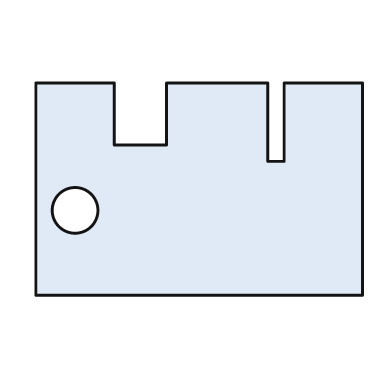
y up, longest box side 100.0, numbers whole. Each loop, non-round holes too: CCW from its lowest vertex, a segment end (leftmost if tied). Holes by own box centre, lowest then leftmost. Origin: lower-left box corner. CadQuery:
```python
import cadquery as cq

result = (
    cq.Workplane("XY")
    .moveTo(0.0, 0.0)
    .lineTo(100.0, 0.0)
    .lineTo(100.0, 65.0)
    .lineTo(76.0, 65.0)
    .lineTo(76.0, 41.0)
    .lineTo(71.0, 41.0)
    .lineTo(71.0, 65.0)
    .lineTo(40.0, 65.0)
    .lineTo(40.0, 46.0)
    .lineTo(24.0, 46.0)
    .lineTo(24.0, 65.0)
    .lineTo(0.0, 65.0)
    .close()
    .moveTo(12.0, 26.0)
    .circle(7.0)
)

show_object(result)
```